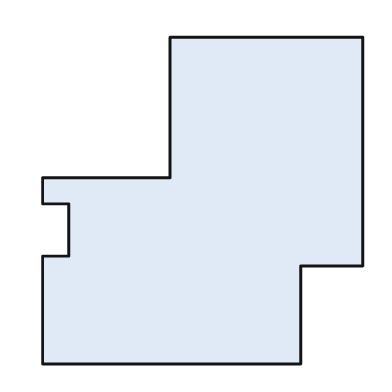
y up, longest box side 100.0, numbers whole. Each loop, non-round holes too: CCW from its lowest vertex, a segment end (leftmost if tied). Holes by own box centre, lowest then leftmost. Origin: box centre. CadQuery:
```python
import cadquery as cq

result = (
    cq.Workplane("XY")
    .moveTo(-49.0, -50.0)
    .lineTo(30.0, -50.0)
    .lineTo(30.0, -20.0)
    .lineTo(49.0, -20.0)
    .lineTo(49.0, 50.0)
    .lineTo(-10.0, 50.0)
    .lineTo(-10.0, 7.0)
    .lineTo(-49.0, 7.0)
    .lineTo(-49.0, -1.0)
    .lineTo(-41.0, -1.0)
    .lineTo(-41.0, -17.0)
    .lineTo(-49.0, -17.0)
    .close()
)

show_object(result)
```